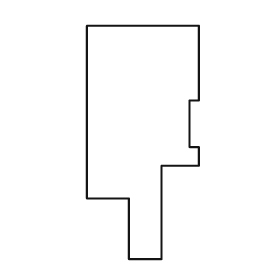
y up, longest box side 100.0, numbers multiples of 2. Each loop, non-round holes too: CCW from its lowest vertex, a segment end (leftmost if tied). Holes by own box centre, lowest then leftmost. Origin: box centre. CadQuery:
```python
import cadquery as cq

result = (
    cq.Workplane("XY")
    .moveTo(-6.0, -50.0)
    .lineTo(8.0, -50.0)
    .lineTo(8.0, -10.0)
    .lineTo(24.0, -10.0)
    .lineTo(24.0, -2.0)
    .lineTo(20.0, -2.0)
    .lineTo(20.0, 18.0)
    .lineTo(24.0, 18.0)
    .lineTo(24.0, 50.0)
    .lineTo(-24.0, 50.0)
    .lineTo(-24.0, -24.0)
    .lineTo(-6.0, -24.0)
    .close()
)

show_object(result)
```